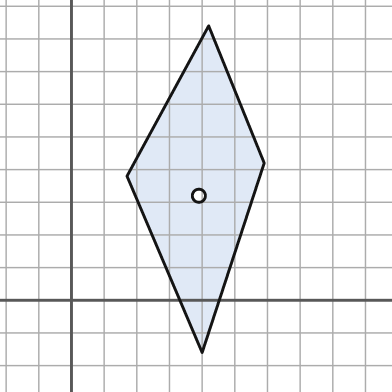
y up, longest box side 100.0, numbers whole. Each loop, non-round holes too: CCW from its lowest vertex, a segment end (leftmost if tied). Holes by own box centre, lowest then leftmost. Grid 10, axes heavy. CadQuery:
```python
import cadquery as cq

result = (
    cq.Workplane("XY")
    .moveTo(40.0, -16.0)
    .lineTo(59.0, 42.0)
    .lineTo(42.0, 84.0)
    .lineTo(17.0, 38.0)
    .close()
    .moveTo(39.0, 32.0)
    .circle(2.0)
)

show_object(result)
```